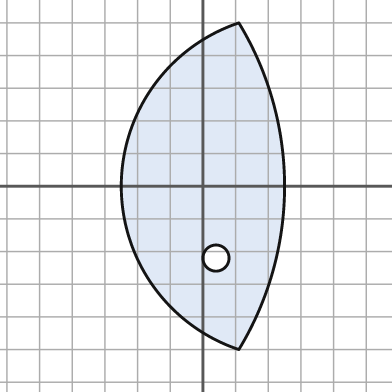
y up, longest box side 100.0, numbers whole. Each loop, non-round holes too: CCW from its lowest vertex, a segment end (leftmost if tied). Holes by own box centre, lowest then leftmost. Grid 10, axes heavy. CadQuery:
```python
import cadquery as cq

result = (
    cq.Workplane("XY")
    .moveTo(11.0, -50.0)
    .threePointArc((25.0, 0.0), (11.0, 50.0))
    .threePointArc((-25.0, 0.0), (11.0, -50.0))
    .close()
    .moveTo(4.0, -22.0)
    .circle(4.0)
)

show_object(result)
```